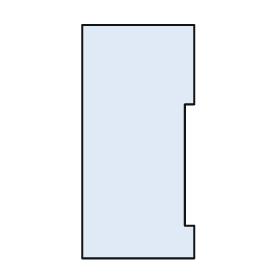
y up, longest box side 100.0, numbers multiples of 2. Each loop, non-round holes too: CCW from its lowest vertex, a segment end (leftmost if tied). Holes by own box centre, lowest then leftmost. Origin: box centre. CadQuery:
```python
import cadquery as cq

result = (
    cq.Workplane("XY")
    .moveTo(-24.0, -50.0)
    .lineTo(24.0, -50.0)
    .lineTo(24.0, -36.0)
    .lineTo(20.0, -36.0)
    .lineTo(20.0, 16.0)
    .lineTo(24.0, 16.0)
    .lineTo(24.0, 50.0)
    .lineTo(-24.0, 50.0)
    .close()
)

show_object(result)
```